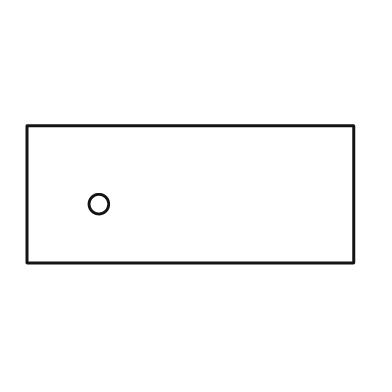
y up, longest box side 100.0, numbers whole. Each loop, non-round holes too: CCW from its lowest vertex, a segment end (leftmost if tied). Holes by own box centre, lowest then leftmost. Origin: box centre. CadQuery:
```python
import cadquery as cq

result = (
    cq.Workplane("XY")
    .moveTo(-50.0, -21.0)
    .lineTo(50.0, -21.0)
    .lineTo(50.0, 21.0)
    .lineTo(-50.0, 21.0)
    .close()
    .moveTo(-28.0, -3.0)
    .circle(3.0)
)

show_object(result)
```